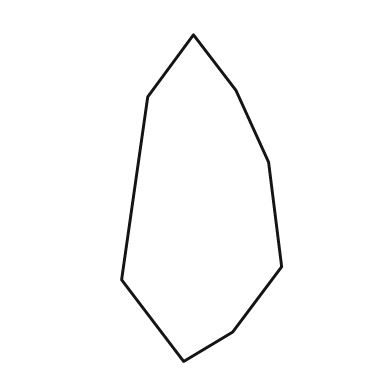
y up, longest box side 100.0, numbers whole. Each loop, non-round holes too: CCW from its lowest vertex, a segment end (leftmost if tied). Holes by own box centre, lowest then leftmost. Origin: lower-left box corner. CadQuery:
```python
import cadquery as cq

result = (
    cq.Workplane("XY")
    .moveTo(19.0, 0.0)
    .lineTo(34.0, 9.0)
    .lineTo(49.0, 29.0)
    .lineTo(45.0, 61.0)
    .lineTo(35.0, 83.0)
    .lineTo(22.0, 100.0)
    .lineTo(8.0, 81.0)
    .lineTo(0.0, 25.0)
    .close()
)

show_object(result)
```